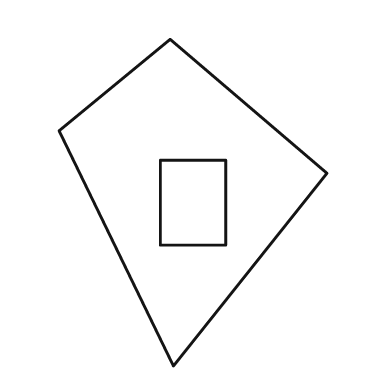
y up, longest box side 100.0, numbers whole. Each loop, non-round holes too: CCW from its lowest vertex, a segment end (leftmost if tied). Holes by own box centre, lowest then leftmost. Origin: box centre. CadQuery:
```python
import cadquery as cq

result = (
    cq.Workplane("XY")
    .moveTo(-6.0, -50.0)
    .lineTo(41.0, 9.0)
    .lineTo(-7.0, 50.0)
    .lineTo(-41.0, 22.0)
    .close()
    .moveTo(-10.0, -13.0)
    .lineTo(10.0, -13.0)
    .lineTo(10.0, 13.0)
    .lineTo(-10.0, 13.0)
    .close()
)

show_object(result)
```